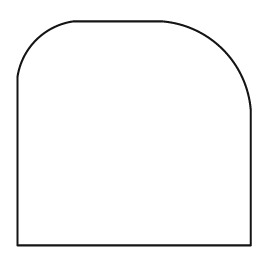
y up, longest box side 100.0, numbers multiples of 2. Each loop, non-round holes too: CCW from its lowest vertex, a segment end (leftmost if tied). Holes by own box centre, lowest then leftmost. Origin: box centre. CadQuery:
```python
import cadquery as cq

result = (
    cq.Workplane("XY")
    .moveTo(-50.0, -48.0)
    .lineTo(50.0, -48.0)
    .lineTo(50.0, 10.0)
    .threePointArc((38.0, 36.0), (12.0, 48.0))
    .lineTo(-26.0, 48.0)
    .threePointArc((-42.0, 40.0), (-50.0, 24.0))
    .close()
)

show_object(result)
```